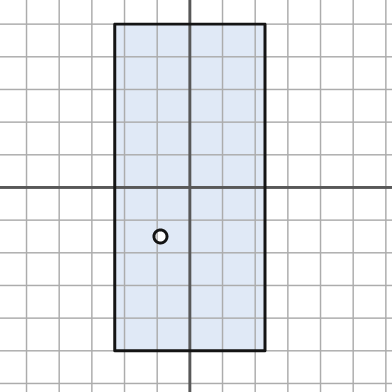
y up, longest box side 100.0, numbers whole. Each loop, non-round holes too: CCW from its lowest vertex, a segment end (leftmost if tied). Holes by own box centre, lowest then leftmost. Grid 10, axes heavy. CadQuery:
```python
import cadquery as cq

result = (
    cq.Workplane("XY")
    .moveTo(-23.0, -50.0)
    .lineTo(23.0, -50.0)
    .lineTo(23.0, 50.0)
    .lineTo(-23.0, 50.0)
    .close()
    .moveTo(-9.0, -15.0)
    .circle(2.0)
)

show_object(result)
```